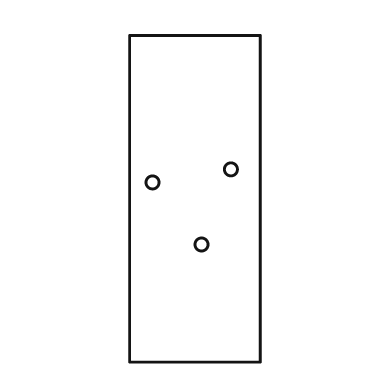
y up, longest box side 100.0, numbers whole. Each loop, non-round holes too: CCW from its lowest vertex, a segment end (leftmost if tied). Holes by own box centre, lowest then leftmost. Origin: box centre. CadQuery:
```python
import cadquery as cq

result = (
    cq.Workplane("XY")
    .moveTo(-20.0, -50.0)
    .lineTo(20.0, -50.0)
    .lineTo(20.0, 50.0)
    .lineTo(-20.0, 50.0)
    .close()
    .moveTo(2.0, -14.0)
    .circle(2.0)
    .moveTo(-13.0, 5.0)
    .circle(2.0)
    .moveTo(11.0, 9.0)
    .circle(2.0)
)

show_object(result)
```